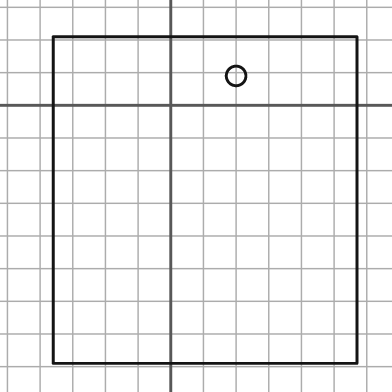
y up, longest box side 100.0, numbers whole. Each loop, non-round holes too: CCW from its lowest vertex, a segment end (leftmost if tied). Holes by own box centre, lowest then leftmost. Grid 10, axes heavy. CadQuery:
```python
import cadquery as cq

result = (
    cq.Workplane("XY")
    .moveTo(-36.0, -79.0)
    .lineTo(57.0, -79.0)
    .lineTo(57.0, 21.0)
    .lineTo(-36.0, 21.0)
    .close()
    .moveTo(20.0, 9.0)
    .circle(3.0)
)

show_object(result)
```